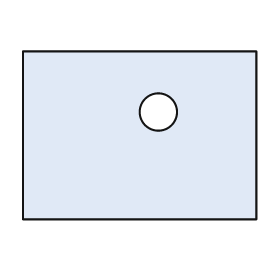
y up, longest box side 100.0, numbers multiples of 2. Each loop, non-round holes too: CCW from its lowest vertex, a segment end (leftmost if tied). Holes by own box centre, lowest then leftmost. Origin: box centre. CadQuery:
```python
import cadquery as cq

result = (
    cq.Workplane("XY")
    .moveTo(-50.0, -36.0)
    .lineTo(50.0, -36.0)
    .lineTo(50.0, 36.0)
    .lineTo(-50.0, 36.0)
    .close()
    .moveTo(8.0, 10.0)
    .circle(8.0)
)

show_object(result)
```